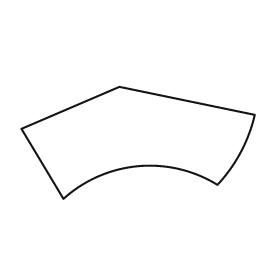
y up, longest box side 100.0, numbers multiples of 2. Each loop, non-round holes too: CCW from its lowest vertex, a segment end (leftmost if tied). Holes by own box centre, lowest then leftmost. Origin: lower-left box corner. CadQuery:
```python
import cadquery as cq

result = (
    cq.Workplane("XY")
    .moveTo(18.0, 0.0)
    .threePointArc((50.0, 14.0), (84.0, 6.0))
    .threePointArc((94.0, 20.0), (100.0, 36.0))
    .lineTo(42.0, 48.0)
    .lineTo(0.0, 30.0)
    .close()
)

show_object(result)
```